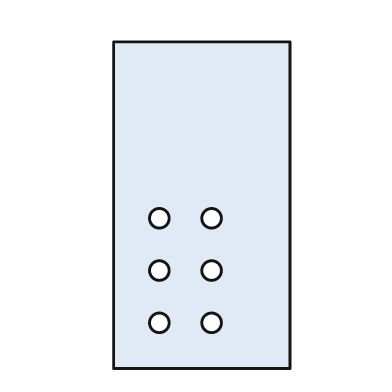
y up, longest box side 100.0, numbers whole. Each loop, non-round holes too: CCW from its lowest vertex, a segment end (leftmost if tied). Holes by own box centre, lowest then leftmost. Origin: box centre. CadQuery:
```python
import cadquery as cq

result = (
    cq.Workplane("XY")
    .moveTo(-27.0, -50.0)
    .lineTo(27.0, -50.0)
    .lineTo(27.0, 50.0)
    .lineTo(-27.0, 50.0)
    .close()
    .moveTo(-13.0, -36.0)
    .circle(3.0)
    .moveTo(3.0, -36.0)
    .circle(3.0)
    .moveTo(-13.0, -20.0)
    .circle(3.0)
    .moveTo(3.0, -20.0)
    .circle(3.0)
    .moveTo(-13.0, -4.0)
    .circle(3.0)
    .moveTo(3.0, -4.0)
    .circle(3.0)
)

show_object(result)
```